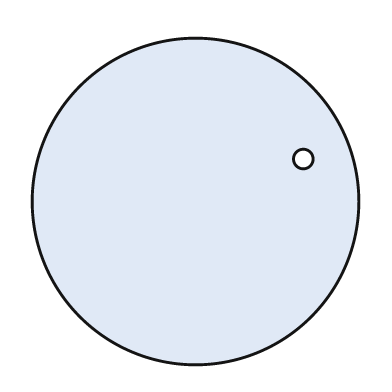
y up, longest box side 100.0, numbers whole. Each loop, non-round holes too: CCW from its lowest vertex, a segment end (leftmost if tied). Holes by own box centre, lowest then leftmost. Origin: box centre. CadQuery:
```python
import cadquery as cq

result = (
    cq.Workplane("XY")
    .moveTo(0.0, 0.0)
    .circle(50.0)
    .moveTo(33.0, 13.0)
    .circle(3.0)
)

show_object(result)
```